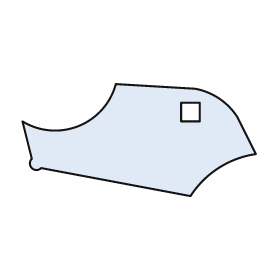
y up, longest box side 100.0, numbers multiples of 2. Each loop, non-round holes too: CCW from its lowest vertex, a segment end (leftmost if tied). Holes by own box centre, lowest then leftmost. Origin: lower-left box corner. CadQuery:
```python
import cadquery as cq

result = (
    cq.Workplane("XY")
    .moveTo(72.0, 0.0)
    .threePointArc((84.0, 12.0), (100.0, 18.0))
    .lineTo(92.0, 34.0)
    .threePointArc((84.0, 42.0), (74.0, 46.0))
    .lineTo(40.0, 48.0)
    .threePointArc((24.0, 30.0), (0.0, 32.0))
    .lineTo(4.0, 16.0)
    .threePointArc((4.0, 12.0), (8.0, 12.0))
    .close()
    .moveTo(68.0, 32.0)
    .lineTo(76.0, 32.0)
    .lineTo(76.0, 40.0)
    .lineTo(68.0, 40.0)
    .close()
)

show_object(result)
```